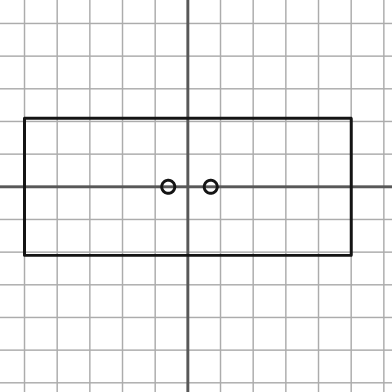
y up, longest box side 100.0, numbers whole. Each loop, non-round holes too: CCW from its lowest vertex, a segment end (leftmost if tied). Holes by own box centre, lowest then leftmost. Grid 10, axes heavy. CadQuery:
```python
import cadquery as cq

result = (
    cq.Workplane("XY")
    .moveTo(-50.0, -21.0)
    .lineTo(50.0, -21.0)
    .lineTo(50.0, 21.0)
    .lineTo(-50.0, 21.0)
    .close()
    .moveTo(-6.0, 0.0)
    .circle(2.0)
    .moveTo(7.0, 0.0)
    .circle(2.0)
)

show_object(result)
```